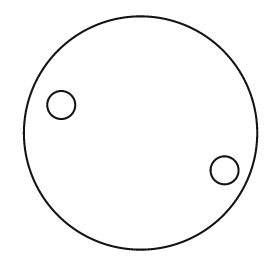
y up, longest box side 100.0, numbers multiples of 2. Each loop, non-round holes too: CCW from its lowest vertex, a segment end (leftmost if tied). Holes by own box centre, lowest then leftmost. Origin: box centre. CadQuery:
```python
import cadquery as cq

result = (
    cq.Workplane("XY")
    .moveTo(0.0, 0.0)
    .circle(50.0)
    .moveTo(36.0, -16.0)
    .circle(6.0)
    .moveTo(-34.0, 12.0)
    .circle(6.0)
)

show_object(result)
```